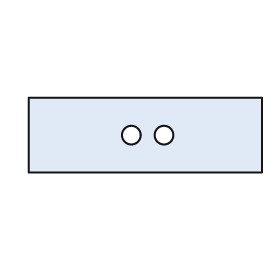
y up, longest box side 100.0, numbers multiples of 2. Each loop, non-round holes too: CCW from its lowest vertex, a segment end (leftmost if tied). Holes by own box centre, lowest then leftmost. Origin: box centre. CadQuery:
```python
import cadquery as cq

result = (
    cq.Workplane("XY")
    .moveTo(-50.0, -16.0)
    .lineTo(50.0, -16.0)
    .lineTo(50.0, 16.0)
    .lineTo(-50.0, 16.0)
    .close()
    .moveTo(-6.0, 0.0)
    .circle(4.0)
    .moveTo(8.0, 0.0)
    .circle(4.0)
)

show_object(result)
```